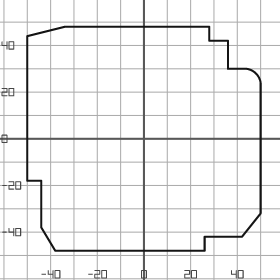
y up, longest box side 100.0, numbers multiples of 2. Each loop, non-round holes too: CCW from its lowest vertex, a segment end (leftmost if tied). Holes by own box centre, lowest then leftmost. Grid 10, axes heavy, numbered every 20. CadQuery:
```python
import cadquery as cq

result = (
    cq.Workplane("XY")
    .moveTo(-38.0, -48.0)
    .lineTo(26.0, -48.0)
    .lineTo(26.0, -42.0)
    .lineTo(42.0, -42.0)
    .lineTo(50.0, -32.0)
    .lineTo(50.0, 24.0)
    .threePointArc((48.0, 28.0), (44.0, 30.0))
    .lineTo(36.0, 30.0)
    .lineTo(36.0, 42.0)
    .lineTo(28.0, 42.0)
    .lineTo(28.0, 48.0)
    .lineTo(-34.0, 48.0)
    .lineTo(-50.0, 44.0)
    .lineTo(-50.0, -18.0)
    .lineTo(-44.0, -18.0)
    .lineTo(-44.0, -38.0)
    .close()
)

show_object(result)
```